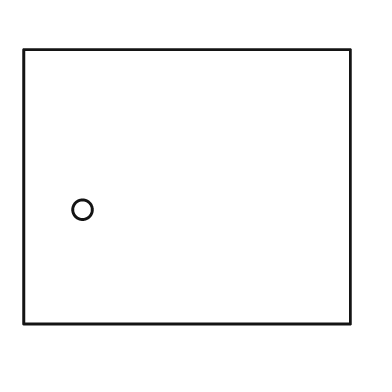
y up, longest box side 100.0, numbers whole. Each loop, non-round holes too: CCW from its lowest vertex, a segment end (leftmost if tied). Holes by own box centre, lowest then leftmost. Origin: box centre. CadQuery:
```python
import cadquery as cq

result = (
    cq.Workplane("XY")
    .moveTo(-50.0, -42.0)
    .lineTo(50.0, -42.0)
    .lineTo(50.0, 42.0)
    .lineTo(-50.0, 42.0)
    .close()
    .moveTo(-32.0, -7.0)
    .circle(3.0)
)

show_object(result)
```